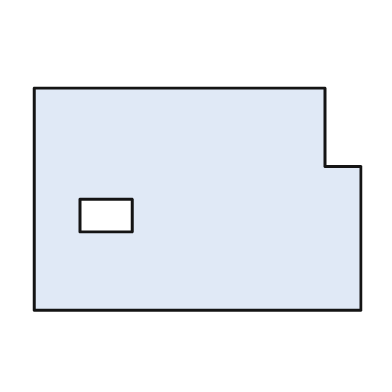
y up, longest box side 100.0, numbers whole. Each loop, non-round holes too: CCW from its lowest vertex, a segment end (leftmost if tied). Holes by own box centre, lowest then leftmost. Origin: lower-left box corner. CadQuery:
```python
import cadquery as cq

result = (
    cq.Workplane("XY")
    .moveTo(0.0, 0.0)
    .lineTo(100.0, 0.0)
    .lineTo(100.0, 44.0)
    .lineTo(89.0, 44.0)
    .lineTo(89.0, 68.0)
    .lineTo(0.0, 68.0)
    .close()
    .moveTo(14.0, 24.0)
    .lineTo(30.0, 24.0)
    .lineTo(30.0, 34.0)
    .lineTo(14.0, 34.0)
    .close()
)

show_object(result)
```